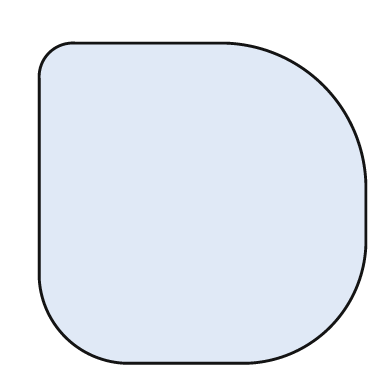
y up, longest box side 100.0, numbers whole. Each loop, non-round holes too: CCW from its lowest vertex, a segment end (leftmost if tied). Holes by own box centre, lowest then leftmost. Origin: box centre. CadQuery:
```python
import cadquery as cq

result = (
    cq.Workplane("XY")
    .moveTo(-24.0, -49.0)
    .lineTo(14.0, -49.0)
    .threePointArc((39.0, -38.0), (50.0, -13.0))
    .lineTo(50.0, 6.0)
    .threePointArc((37.0, 36.0), (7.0, 49.0))
    .lineTo(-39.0, 49.0)
    .threePointArc((-47.0, 46.0), (-50.0, 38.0))
    .lineTo(-50.0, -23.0)
    .threePointArc((-42.0, -41.0), (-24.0, -49.0))
    .close()
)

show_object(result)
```